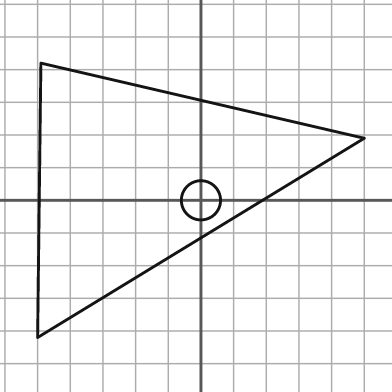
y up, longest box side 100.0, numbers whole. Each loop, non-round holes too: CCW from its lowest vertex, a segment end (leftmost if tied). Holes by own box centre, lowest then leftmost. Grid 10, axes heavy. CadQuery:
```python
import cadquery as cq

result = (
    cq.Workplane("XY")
    .moveTo(-50.0, -42.0)
    .lineTo(50.0, 19.0)
    .lineTo(-49.0, 42.0)
    .close()
    .moveTo(0.0, 0.0)
    .circle(6.0)
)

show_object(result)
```